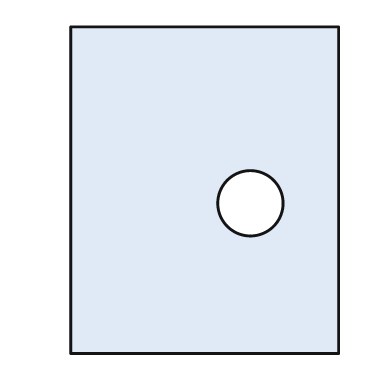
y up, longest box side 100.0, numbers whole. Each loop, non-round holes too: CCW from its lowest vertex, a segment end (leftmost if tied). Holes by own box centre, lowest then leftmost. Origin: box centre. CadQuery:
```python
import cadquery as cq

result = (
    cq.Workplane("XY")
    .moveTo(-41.0, -50.0)
    .lineTo(41.0, -50.0)
    .lineTo(41.0, 50.0)
    .lineTo(-41.0, 50.0)
    .close()
    .moveTo(14.0, -4.0)
    .circle(10.0)
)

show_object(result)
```